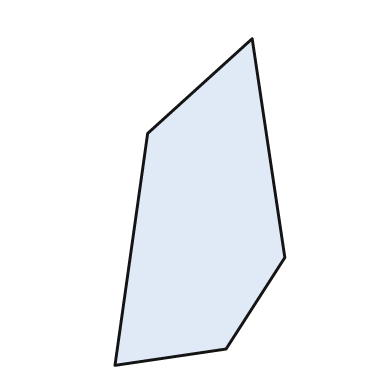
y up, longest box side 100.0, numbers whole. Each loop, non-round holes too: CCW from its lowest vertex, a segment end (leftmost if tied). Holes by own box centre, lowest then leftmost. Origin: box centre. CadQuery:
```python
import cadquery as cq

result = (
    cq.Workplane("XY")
    .moveTo(-26.0, -50.0)
    .lineTo(8.0, -45.0)
    .lineTo(26.0, -17.0)
    .lineTo(16.0, 50.0)
    .lineTo(-16.0, 21.0)
    .close()
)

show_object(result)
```